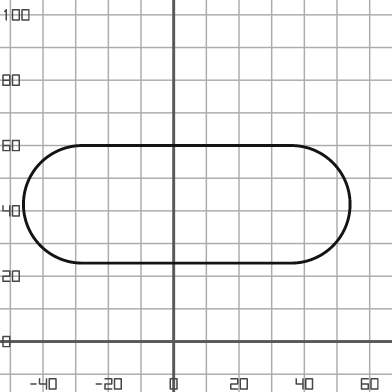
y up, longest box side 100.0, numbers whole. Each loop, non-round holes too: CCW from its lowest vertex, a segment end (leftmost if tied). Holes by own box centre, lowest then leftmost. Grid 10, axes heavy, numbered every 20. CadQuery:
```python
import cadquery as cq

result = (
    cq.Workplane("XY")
    .moveTo(-28.0, 24.0)
    .lineTo(36.0, 24.0)
    .threePointArc((54.0, 42.0), (36.0, 60.0))
    .lineTo(-28.0, 60.0)
    .threePointArc((-46.0, 42.0), (-28.0, 24.0))
    .close()
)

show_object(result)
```